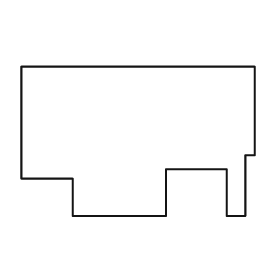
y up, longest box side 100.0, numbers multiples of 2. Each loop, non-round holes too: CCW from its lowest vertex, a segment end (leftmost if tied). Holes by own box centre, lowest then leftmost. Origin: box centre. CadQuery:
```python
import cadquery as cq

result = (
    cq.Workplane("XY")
    .moveTo(-28.0, -32.0)
    .lineTo(12.0, -32.0)
    .lineTo(12.0, -12.0)
    .lineTo(38.0, -12.0)
    .lineTo(38.0, -32.0)
    .lineTo(46.0, -32.0)
    .lineTo(46.0, -6.0)
    .lineTo(50.0, -6.0)
    .lineTo(50.0, 32.0)
    .lineTo(-50.0, 32.0)
    .lineTo(-50.0, -16.0)
    .lineTo(-28.0, -16.0)
    .close()
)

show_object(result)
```